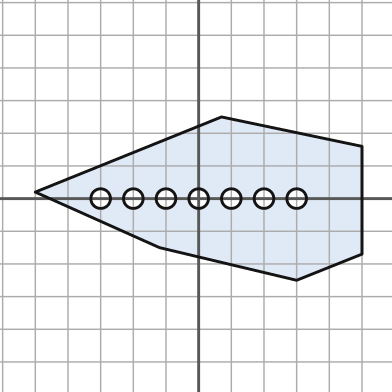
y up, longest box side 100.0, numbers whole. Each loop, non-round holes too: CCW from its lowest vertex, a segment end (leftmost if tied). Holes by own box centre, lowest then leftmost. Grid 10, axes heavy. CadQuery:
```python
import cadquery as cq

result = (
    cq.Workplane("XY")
    .moveTo(30.0, -25.0)
    .lineTo(50.0, -17.0)
    .lineTo(50.0, 16.0)
    .lineTo(7.0, 25.0)
    .lineTo(-50.0, 2.0)
    .lineTo(-12.0, -15.0)
    .close()
    .moveTo(-30.0, 0.0)
    .circle(3.0)
    .moveTo(-20.0, 0.0)
    .circle(3.0)
    .moveTo(-10.0, 0.0)
    .circle(3.0)
    .moveTo(0.0, 0.0)
    .circle(3.0)
    .moveTo(10.0, 0.0)
    .circle(3.0)
    .moveTo(20.0, 0.0)
    .circle(3.0)
    .moveTo(30.0, 0.0)
    .circle(3.0)
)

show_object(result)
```